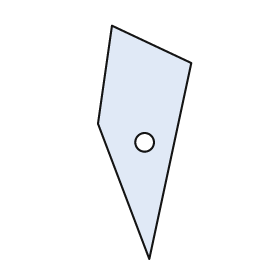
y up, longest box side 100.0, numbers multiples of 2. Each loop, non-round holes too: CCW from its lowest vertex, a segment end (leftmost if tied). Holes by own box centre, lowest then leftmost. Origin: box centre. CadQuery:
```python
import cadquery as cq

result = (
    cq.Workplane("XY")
    .moveTo(2.0, -50.0)
    .lineTo(20.0, 34.0)
    .lineTo(-14.0, 50.0)
    .lineTo(-20.0, 8.0)
    .close()
    .moveTo(0.0, 0.0)
    .circle(4.0)
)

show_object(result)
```